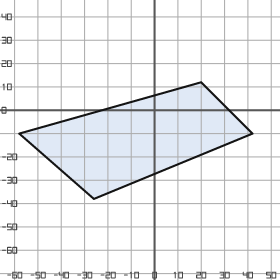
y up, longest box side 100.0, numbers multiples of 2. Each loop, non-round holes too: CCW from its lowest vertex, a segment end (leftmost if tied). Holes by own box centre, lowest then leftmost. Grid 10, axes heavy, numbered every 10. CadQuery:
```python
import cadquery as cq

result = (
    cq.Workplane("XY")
    .moveTo(-26.0, -38.0)
    .lineTo(42.0, -10.0)
    .lineTo(20.0, 12.0)
    .lineTo(-58.0, -10.0)
    .close()
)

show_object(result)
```